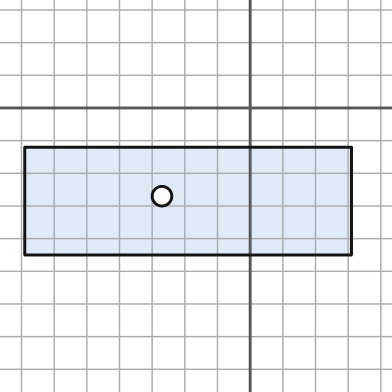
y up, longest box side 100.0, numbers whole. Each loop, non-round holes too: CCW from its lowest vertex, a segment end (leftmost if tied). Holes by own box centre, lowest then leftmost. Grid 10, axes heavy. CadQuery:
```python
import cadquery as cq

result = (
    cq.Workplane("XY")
    .moveTo(-69.0, -45.0)
    .lineTo(31.0, -45.0)
    .lineTo(31.0, -12.0)
    .lineTo(-69.0, -12.0)
    .close()
    .moveTo(-27.0, -27.0)
    .circle(3.0)
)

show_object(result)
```